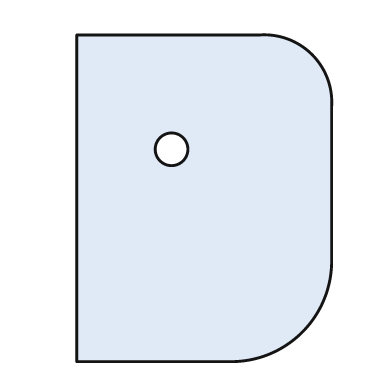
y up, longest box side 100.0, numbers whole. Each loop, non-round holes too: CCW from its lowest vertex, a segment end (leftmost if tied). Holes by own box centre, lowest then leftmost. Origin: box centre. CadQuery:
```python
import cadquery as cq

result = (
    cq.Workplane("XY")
    .moveTo(-39.0, -50.0)
    .lineTo(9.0, -50.0)
    .threePointArc((30.0, -41.0), (39.0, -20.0))
    .lineTo(39.0, 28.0)
    .threePointArc((33.0, 44.0), (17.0, 50.0))
    .lineTo(-39.0, 50.0)
    .close()
    .moveTo(-10.0, 15.0)
    .circle(5.0)
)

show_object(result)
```